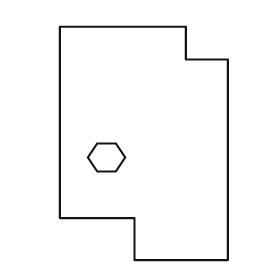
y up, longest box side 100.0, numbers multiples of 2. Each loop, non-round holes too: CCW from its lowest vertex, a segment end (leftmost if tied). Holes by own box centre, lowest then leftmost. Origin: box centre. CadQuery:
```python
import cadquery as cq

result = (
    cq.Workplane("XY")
    .moveTo(-4.0, -50.0)
    .lineTo(36.0, -50.0)
    .lineTo(36.0, 36.0)
    .lineTo(18.0, 36.0)
    .lineTo(18.0, 50.0)
    .lineTo(-36.0, 50.0)
    .lineTo(-36.0, -32.0)
    .lineTo(-4.0, -32.0)
    .close()
    .moveTo(-20.0, -12.0)
    .lineTo(-12.0, -12.0)
    .lineTo(-8.0, -6.0)
    .lineTo(-12.0, 0.0)
    .lineTo(-20.0, 0.0)
    .lineTo(-24.0, -6.0)
    .close()
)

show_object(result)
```